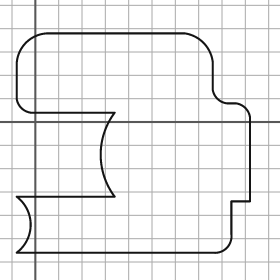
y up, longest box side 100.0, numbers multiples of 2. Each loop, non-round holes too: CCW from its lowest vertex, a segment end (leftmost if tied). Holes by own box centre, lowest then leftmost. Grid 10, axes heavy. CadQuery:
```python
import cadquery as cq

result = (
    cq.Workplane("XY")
    .moveTo(-8.0, -56.0)
    .lineTo(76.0, -56.0)
    .threePointArc((82.0, -54.0), (84.0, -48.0))
    .lineTo(84.0, -34.0)
    .lineTo(92.0, -34.0)
    .lineTo(92.0, 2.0)
    .threePointArc((90.0, 6.0), (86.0, 8.0))
    .lineTo(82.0, 8.0)
    .threePointArc((78.0, 10.0), (76.0, 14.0))
    .lineTo(76.0, 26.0)
    .threePointArc((72.0, 34.0), (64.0, 38.0))
    .lineTo(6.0, 38.0)
    .threePointArc((-4.0, 34.0), (-8.0, 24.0))
    .lineTo(-8.0, 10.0)
    .threePointArc((-6.0, 6.0), (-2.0, 4.0))
    .lineTo(34.0, 4.0)
    .threePointArc((28.0, -14.0), (34.0, -32.0))
    .lineTo(-8.0, -32.0)
    .threePointArc((-2.0, -44.0), (-8.0, -56.0))
    .close()
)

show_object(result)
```